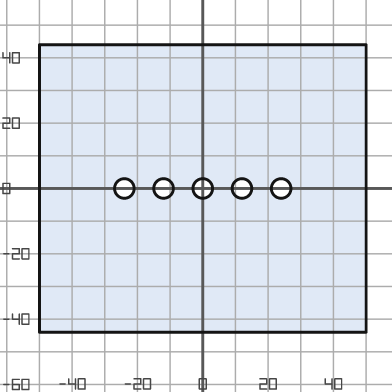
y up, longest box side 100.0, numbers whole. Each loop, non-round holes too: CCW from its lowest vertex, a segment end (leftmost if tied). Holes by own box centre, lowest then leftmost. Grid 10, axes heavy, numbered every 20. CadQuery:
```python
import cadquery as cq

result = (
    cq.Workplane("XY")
    .moveTo(-50.0, -44.0)
    .lineTo(50.0, -44.0)
    .lineTo(50.0, 44.0)
    .lineTo(-50.0, 44.0)
    .close()
    .moveTo(-24.0, 0.0)
    .circle(3.0)
    .moveTo(-12.0, 0.0)
    .circle(3.0)
    .moveTo(0.0, 0.0)
    .circle(3.0)
    .moveTo(12.0, 0.0)
    .circle(3.0)
    .moveTo(24.0, 0.0)
    .circle(3.0)
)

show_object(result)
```